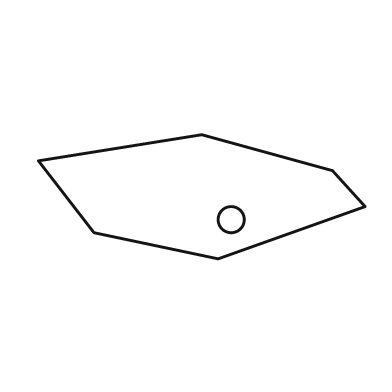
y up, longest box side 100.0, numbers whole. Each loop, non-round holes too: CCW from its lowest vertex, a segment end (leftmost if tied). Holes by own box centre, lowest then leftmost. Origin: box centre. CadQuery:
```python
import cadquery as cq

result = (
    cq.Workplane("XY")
    .moveTo(5.0, -19.0)
    .lineTo(50.0, -3.0)
    .lineTo(40.0, 8.0)
    .lineTo(0.0, 19.0)
    .lineTo(-50.0, 11.0)
    .lineTo(-33.0, -11.0)
    .close()
    .moveTo(9.0, -7.0)
    .circle(4.0)
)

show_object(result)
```